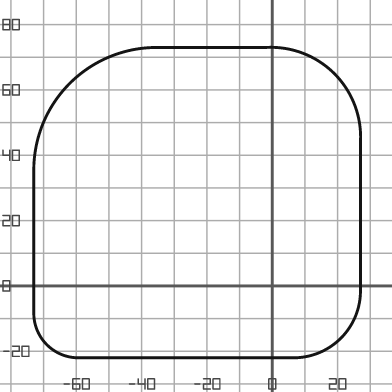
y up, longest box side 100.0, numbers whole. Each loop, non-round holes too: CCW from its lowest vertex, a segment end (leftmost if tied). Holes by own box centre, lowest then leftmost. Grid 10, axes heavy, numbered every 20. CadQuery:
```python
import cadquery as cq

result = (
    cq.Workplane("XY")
    .moveTo(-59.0, -22.0)
    .lineTo(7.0, -22.0)
    .threePointArc((21.0, -16.0), (27.0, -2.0))
    .lineTo(27.0, 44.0)
    .threePointArc((19.0, 65.0), (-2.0, 73.0))
    .lineTo(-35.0, 73.0)
    .threePointArc((-62.0, 62.0), (-73.0, 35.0))
    .lineTo(-73.0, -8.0)
    .threePointArc((-69.0, -18.0), (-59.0, -22.0))
    .close()
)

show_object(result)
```